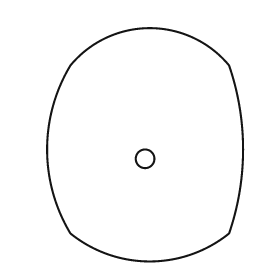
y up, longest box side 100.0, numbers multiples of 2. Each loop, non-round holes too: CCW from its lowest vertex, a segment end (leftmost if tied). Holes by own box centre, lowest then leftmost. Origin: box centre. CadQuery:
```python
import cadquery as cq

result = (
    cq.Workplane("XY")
    .moveTo(-32.0, -38.0)
    .threePointArc((2.0, -50.0), (36.0, -38.0))
    .threePointArc((42.0, -2.0), (36.0, 34.0))
    .threePointArc((2.0, 50.0), (-32.0, 34.0))
    .threePointArc((-42.0, -2.0), (-32.0, -38.0))
    .close()
    .moveTo(0.0, -6.0)
    .circle(4.0)
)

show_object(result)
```